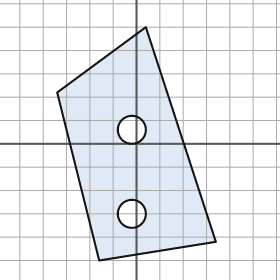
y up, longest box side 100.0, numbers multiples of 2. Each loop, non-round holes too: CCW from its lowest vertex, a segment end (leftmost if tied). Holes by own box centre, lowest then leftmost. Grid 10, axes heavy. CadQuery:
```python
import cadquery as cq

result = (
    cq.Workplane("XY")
    .moveTo(-16.0, -50.0)
    .lineTo(34.0, -42.0)
    .lineTo(4.0, 50.0)
    .lineTo(-34.0, 22.0)
    .close()
    .moveTo(-2.0, -30.0)
    .circle(6.0)
    .moveTo(-2.0, 6.0)
    .circle(6.0)
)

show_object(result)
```